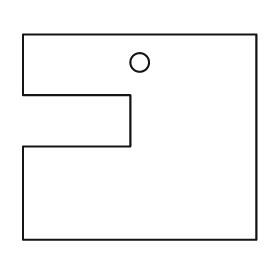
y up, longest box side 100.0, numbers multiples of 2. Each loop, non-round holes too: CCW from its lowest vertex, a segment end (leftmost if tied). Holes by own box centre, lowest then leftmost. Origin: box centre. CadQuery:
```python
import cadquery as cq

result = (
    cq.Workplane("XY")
    .moveTo(-50.0, -44.0)
    .lineTo(50.0, -44.0)
    .lineTo(50.0, 44.0)
    .lineTo(-50.0, 44.0)
    .lineTo(-50.0, 18.0)
    .lineTo(-4.0, 18.0)
    .lineTo(-4.0, -4.0)
    .lineTo(-50.0, -4.0)
    .close()
    .moveTo(0.0, 32.0)
    .circle(4.0)
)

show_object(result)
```